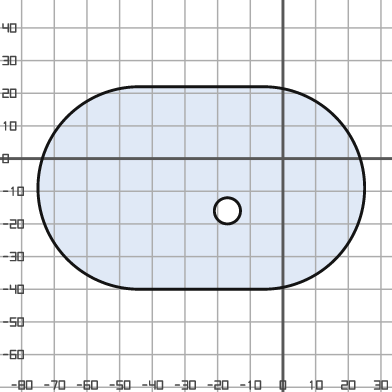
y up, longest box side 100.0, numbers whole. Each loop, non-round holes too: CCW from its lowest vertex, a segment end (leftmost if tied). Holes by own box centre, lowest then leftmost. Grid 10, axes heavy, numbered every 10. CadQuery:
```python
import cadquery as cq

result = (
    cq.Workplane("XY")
    .moveTo(-44.0, -40.0)
    .lineTo(-6.0, -40.0)
    .threePointArc((25.0, -9.0), (-6.0, 22.0))
    .lineTo(-44.0, 22.0)
    .threePointArc((-75.0, -9.0), (-44.0, -40.0))
    .close()
    .moveTo(-17.0, -16.0)
    .circle(4.0)
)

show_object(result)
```